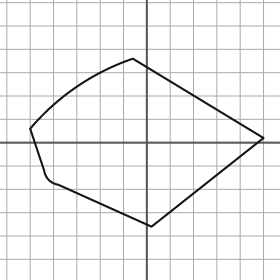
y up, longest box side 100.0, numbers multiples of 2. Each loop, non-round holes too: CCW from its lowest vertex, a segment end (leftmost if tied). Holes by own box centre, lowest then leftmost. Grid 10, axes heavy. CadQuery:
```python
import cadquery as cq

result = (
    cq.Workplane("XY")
    .moveTo(2.0, -36.0)
    .lineTo(50.0, 2.0)
    .lineTo(-6.0, 36.0)
    .threePointArc((-30.0, 24.0), (-50.0, 6.0))
    .lineTo(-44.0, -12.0)
    .threePointArc((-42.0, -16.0), (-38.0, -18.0))
    .close()
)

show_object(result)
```